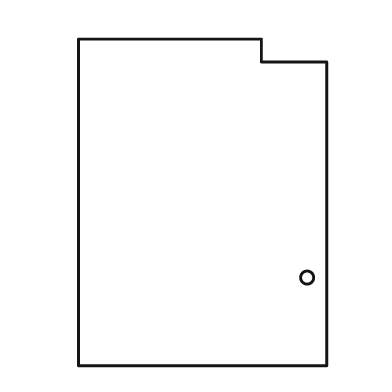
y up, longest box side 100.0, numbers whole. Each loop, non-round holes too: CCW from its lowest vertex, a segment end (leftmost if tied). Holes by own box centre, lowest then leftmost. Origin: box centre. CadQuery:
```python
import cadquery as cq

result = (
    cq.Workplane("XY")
    .moveTo(-38.0, -50.0)
    .lineTo(38.0, -50.0)
    .lineTo(38.0, 43.0)
    .lineTo(18.0, 43.0)
    .lineTo(18.0, 50.0)
    .lineTo(-38.0, 50.0)
    .close()
    .moveTo(32.0, -23.0)
    .circle(2.0)
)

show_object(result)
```